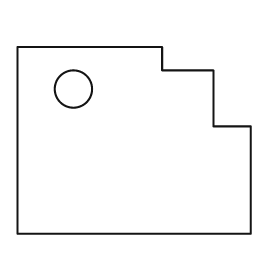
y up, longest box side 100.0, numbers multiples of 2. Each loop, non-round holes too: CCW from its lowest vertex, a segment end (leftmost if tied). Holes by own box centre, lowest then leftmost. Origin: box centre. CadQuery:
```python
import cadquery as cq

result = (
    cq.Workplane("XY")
    .moveTo(-50.0, -40.0)
    .lineTo(50.0, -40.0)
    .lineTo(50.0, 6.0)
    .lineTo(34.0, 6.0)
    .lineTo(34.0, 30.0)
    .lineTo(12.0, 30.0)
    .lineTo(12.0, 40.0)
    .lineTo(-50.0, 40.0)
    .close()
    .moveTo(-26.0, 22.0)
    .circle(8.0)
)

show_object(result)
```